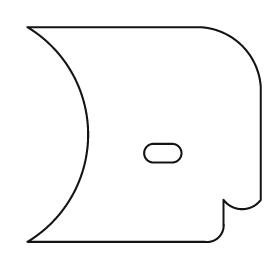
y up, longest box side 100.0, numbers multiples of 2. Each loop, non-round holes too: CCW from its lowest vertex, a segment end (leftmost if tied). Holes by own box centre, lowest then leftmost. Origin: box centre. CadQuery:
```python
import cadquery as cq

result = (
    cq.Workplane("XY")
    .moveTo(-50.0, -46.0)
    .lineTo(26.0, -46.0)
    .threePointArc((32.0, -44.0), (34.0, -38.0))
    .lineTo(34.0, -28.0)
    .threePointArc((42.0, -32.0), (50.0, -28.0))
    .lineTo(50.0, 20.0)
    .threePointArc((42.0, 38.0), (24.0, 46.0))
    .lineTo(-50.0, 46.0)
    .threePointArc((-24.0, 0.0), (-50.0, -46.0))
    .close()
    .moveTo(4.0, -12.0)
    .lineTo(12.0, -12.0)
    .threePointArc((16.0, -8.0), (12.0, -4.0))
    .lineTo(4.0, -4.0)
    .threePointArc((0.0, -8.0), (4.0, -12.0))
    .close()
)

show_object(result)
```